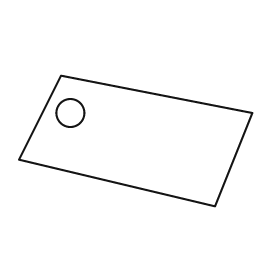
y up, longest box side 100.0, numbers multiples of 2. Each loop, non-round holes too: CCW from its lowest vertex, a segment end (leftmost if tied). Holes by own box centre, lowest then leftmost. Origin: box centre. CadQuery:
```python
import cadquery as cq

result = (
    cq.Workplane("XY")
    .moveTo(34.0, -28.0)
    .lineTo(50.0, 12.0)
    .lineTo(-32.0, 28.0)
    .lineTo(-50.0, -8.0)
    .close()
    .moveTo(-28.0, 12.0)
    .circle(6.0)
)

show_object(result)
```